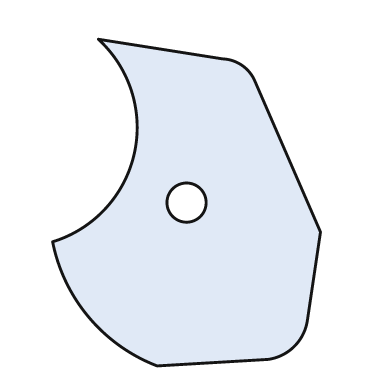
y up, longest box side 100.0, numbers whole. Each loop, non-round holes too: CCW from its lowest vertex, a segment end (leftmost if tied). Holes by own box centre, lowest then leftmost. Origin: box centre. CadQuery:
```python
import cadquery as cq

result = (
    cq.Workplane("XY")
    .moveTo(-9.0, -50.0)
    .lineTo(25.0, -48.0)
    .threePointArc((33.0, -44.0), (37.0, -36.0))
    .lineTo(41.0, -9.0)
    .lineTo(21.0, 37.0)
    .threePointArc((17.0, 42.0), (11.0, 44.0))
    .lineTo(-27.0, 50.0)
    .threePointArc((-16.0, 15.0), (-41.0, -12.0))
    .threePointArc((-30.0, -35.0), (-9.0, -50.0))
    .close()
    .moveTo(0.0, 0.0)
    .circle(6.0)
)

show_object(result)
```